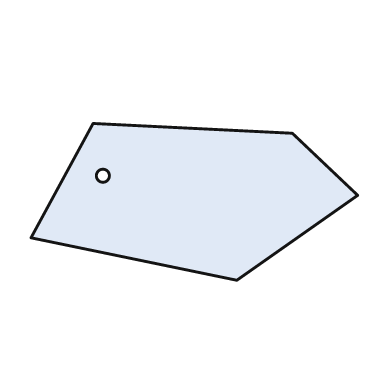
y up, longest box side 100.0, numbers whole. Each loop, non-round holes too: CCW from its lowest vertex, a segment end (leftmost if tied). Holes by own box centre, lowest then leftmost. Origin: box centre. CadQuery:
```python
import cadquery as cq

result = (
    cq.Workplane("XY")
    .moveTo(13.0, -24.0)
    .lineTo(50.0, 2.0)
    .lineTo(30.0, 21.0)
    .lineTo(-31.0, 24.0)
    .lineTo(-50.0, -11.0)
    .close()
    .moveTo(-28.0, 8.0)
    .circle(2.0)
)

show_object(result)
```